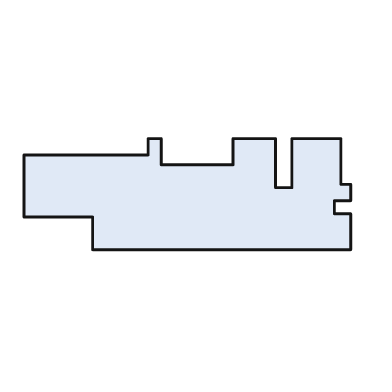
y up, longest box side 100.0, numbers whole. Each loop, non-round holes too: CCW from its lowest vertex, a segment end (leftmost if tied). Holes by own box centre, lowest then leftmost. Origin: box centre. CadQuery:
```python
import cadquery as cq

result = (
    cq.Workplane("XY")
    .moveTo(-29.0, -17.0)
    .lineTo(50.0, -17.0)
    .lineTo(50.0, -6.0)
    .lineTo(45.0, -6.0)
    .lineTo(45.0, -2.0)
    .lineTo(50.0, -2.0)
    .lineTo(50.0, 3.0)
    .lineTo(47.0, 3.0)
    .lineTo(47.0, 17.0)
    .lineTo(32.0, 17.0)
    .lineTo(32.0, 2.0)
    .lineTo(27.0, 2.0)
    .lineTo(27.0, 17.0)
    .lineTo(14.0, 17.0)
    .lineTo(14.0, 9.0)
    .lineTo(-8.0, 9.0)
    .lineTo(-8.0, 17.0)
    .lineTo(-12.0, 17.0)
    .lineTo(-12.0, 12.0)
    .lineTo(-50.0, 12.0)
    .lineTo(-50.0, -7.0)
    .lineTo(-29.0, -7.0)
    .close()
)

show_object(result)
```